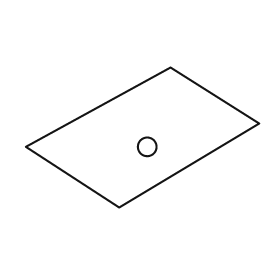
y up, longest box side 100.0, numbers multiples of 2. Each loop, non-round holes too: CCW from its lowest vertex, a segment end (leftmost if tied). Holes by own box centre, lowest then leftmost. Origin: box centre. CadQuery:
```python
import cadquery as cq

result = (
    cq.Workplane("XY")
    .moveTo(-10.0, -30.0)
    .lineTo(50.0, 6.0)
    .lineTo(12.0, 30.0)
    .lineTo(-50.0, -4.0)
    .close()
    .moveTo(2.0, -4.0)
    .circle(4.0)
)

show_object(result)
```